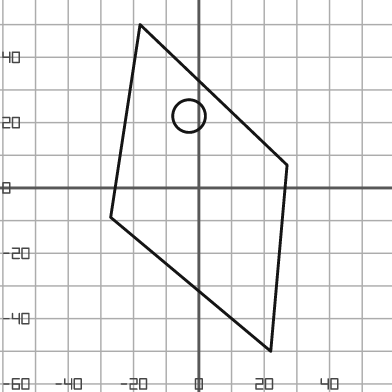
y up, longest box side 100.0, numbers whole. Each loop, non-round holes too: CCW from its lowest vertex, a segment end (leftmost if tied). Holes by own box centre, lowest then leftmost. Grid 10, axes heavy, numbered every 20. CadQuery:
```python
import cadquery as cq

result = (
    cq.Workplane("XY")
    .moveTo(22.0, -50.0)
    .lineTo(27.0, 7.0)
    .lineTo(-18.0, 50.0)
    .lineTo(-27.0, -9.0)
    .close()
    .moveTo(-3.0, 22.0)
    .circle(5.0)
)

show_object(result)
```